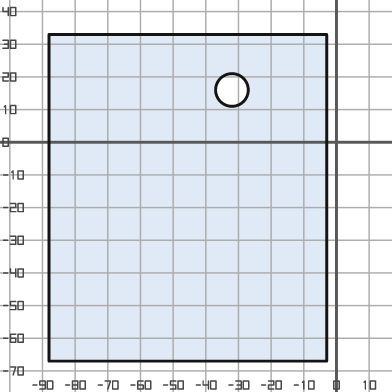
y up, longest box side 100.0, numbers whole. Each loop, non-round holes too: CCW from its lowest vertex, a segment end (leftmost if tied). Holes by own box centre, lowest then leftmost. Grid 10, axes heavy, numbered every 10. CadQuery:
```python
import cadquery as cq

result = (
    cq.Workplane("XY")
    .moveTo(-88.0, -67.0)
    .lineTo(-3.0, -67.0)
    .lineTo(-3.0, 33.0)
    .lineTo(-88.0, 33.0)
    .close()
    .moveTo(-32.0, 16.0)
    .circle(5.0)
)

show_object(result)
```